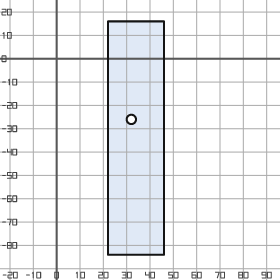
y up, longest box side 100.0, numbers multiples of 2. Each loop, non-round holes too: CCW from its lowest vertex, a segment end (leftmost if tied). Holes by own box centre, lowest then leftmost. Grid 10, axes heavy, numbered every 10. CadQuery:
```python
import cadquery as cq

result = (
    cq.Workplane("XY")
    .moveTo(22.0, -84.0)
    .lineTo(46.0, -84.0)
    .lineTo(46.0, 16.0)
    .lineTo(22.0, 16.0)
    .close()
    .moveTo(32.0, -26.0)
    .circle(2.0)
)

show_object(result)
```